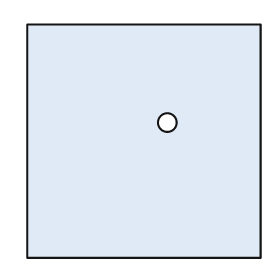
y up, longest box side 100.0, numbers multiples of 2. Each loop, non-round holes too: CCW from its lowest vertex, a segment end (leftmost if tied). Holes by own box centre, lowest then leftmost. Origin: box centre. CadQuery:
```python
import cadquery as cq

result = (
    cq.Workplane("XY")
    .moveTo(-50.0, -50.0)
    .lineTo(50.0, -50.0)
    .lineTo(50.0, 50.0)
    .lineTo(-50.0, 50.0)
    .close()
    .moveTo(10.0, 8.0)
    .circle(4.0)
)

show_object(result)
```